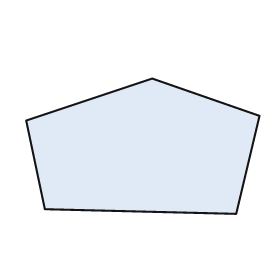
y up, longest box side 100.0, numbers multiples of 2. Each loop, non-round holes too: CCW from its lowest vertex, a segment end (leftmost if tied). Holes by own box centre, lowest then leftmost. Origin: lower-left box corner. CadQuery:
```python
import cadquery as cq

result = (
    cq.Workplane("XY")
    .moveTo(90.0, 0.0)
    .lineTo(100.0, 42.0)
    .lineTo(54.0, 58.0)
    .lineTo(0.0, 40.0)
    .lineTo(8.0, 2.0)
    .close()
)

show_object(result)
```